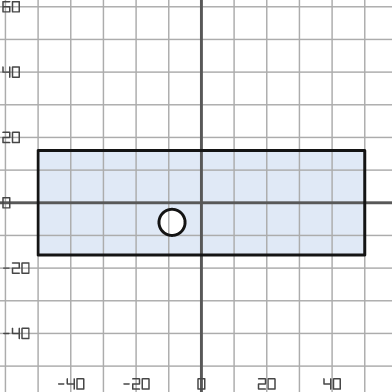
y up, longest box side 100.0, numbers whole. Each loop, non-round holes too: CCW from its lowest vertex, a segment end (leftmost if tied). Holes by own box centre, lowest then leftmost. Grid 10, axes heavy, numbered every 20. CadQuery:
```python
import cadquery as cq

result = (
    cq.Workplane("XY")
    .moveTo(-50.0, -16.0)
    .lineTo(50.0, -16.0)
    .lineTo(50.0, 16.0)
    .lineTo(-50.0, 16.0)
    .close()
    .moveTo(-9.0, -6.0)
    .circle(4.0)
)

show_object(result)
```